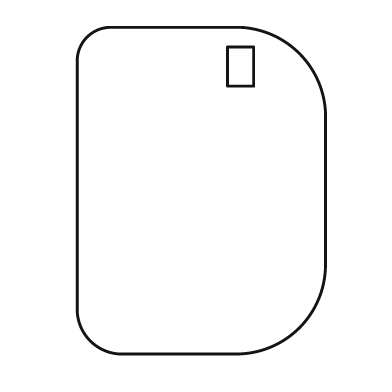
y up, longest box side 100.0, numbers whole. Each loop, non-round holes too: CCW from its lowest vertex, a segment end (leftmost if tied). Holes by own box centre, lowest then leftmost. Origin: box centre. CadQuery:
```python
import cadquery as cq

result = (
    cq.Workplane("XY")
    .moveTo(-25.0, -50.0)
    .lineTo(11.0, -50.0)
    .threePointArc((30.0, -42.0), (38.0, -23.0))
    .lineTo(38.0, 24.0)
    .threePointArc((30.0, 42.0), (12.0, 50.0))
    .lineTo(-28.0, 50.0)
    .threePointArc((-35.0, 47.0), (-38.0, 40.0))
    .lineTo(-38.0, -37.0)
    .threePointArc((-34.0, -46.0), (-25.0, -50.0))
    .close()
    .moveTo(8.0, 32.0)
    .lineTo(16.0, 32.0)
    .lineTo(16.0, 44.0)
    .lineTo(8.0, 44.0)
    .close()
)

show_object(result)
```